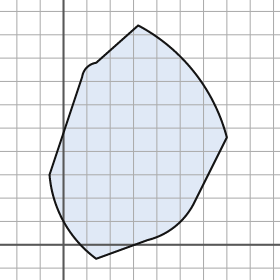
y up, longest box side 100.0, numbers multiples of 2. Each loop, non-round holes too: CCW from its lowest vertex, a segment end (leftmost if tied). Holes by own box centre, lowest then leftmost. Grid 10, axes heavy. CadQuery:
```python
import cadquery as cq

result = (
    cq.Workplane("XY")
    .moveTo(14.0, -6.0)
    .lineTo(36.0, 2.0)
    .threePointArc((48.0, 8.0), (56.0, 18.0))
    .lineTo(70.0, 46.0)
    .threePointArc((56.0, 74.0), (32.0, 94.0))
    .lineTo(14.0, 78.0)
    .threePointArc((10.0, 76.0), (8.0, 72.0))
    .lineTo(-6.0, 30.0)
    .threePointArc((0.0, 10.0), (14.0, -6.0))
    .close()
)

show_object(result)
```